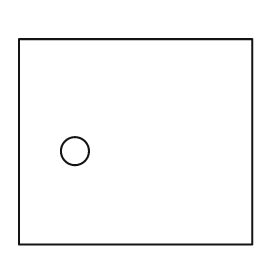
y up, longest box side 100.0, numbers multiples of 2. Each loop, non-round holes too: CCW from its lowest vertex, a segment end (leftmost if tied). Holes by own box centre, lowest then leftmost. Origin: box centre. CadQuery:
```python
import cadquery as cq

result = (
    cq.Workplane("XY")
    .moveTo(-50.0, -44.0)
    .lineTo(50.0, -44.0)
    .lineTo(50.0, 44.0)
    .lineTo(-50.0, 44.0)
    .close()
    .moveTo(-26.0, -4.0)
    .circle(6.0)
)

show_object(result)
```